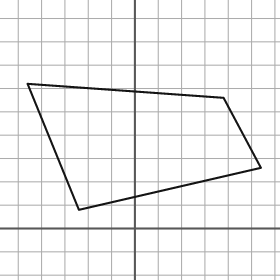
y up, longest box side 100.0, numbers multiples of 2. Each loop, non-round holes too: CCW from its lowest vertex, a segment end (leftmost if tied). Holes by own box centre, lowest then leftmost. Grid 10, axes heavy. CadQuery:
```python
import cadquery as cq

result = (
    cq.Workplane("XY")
    .moveTo(-24.0, 8.0)
    .lineTo(54.0, 26.0)
    .lineTo(38.0, 56.0)
    .lineTo(-46.0, 62.0)
    .close()
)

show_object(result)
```